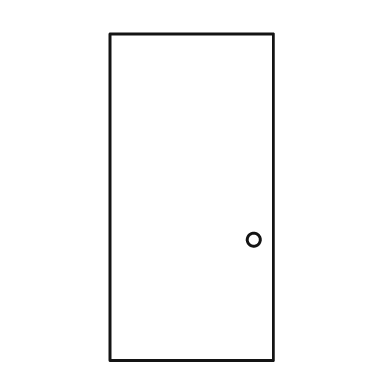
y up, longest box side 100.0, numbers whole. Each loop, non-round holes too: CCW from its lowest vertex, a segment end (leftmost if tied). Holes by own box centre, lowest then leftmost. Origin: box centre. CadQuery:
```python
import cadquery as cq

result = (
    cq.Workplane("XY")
    .moveTo(-25.0, -50.0)
    .lineTo(25.0, -50.0)
    .lineTo(25.0, 50.0)
    .lineTo(-25.0, 50.0)
    .close()
    .moveTo(19.0, -13.0)
    .circle(2.0)
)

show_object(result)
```